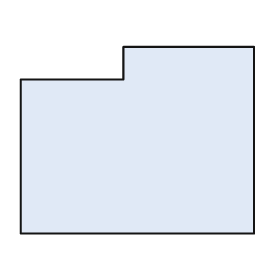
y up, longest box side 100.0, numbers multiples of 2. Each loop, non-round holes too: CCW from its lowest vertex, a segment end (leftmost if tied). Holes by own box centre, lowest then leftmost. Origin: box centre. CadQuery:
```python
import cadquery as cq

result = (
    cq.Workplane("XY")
    .moveTo(-50.0, -40.0)
    .lineTo(50.0, -40.0)
    .lineTo(50.0, 40.0)
    .lineTo(-6.0, 40.0)
    .lineTo(-6.0, 26.0)
    .lineTo(-50.0, 26.0)
    .close()
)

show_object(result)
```